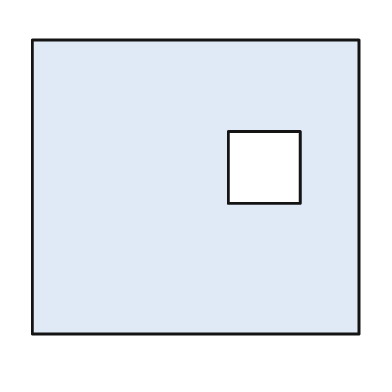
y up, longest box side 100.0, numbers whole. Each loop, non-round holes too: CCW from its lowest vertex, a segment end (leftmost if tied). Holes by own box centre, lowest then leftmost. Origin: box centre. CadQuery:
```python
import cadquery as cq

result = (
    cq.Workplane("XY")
    .moveTo(-50.0, -45.0)
    .lineTo(50.0, -45.0)
    .lineTo(50.0, 45.0)
    .lineTo(-50.0, 45.0)
    .close()
    .moveTo(10.0, -5.0)
    .lineTo(32.0, -5.0)
    .lineTo(32.0, 17.0)
    .lineTo(10.0, 17.0)
    .close()
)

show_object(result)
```